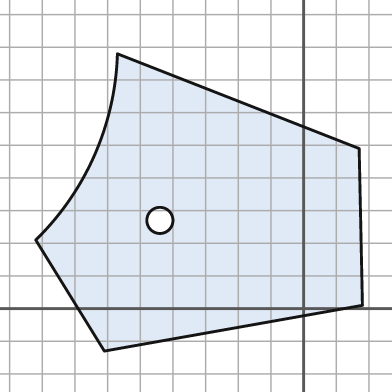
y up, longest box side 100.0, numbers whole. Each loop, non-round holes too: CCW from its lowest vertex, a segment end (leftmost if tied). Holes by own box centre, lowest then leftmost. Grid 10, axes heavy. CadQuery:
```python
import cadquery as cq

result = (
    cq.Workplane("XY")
    .moveTo(-61.0, -13.0)
    .lineTo(18.0, 1.0)
    .lineTo(17.0, 49.0)
    .lineTo(-57.0, 78.0)
    .threePointArc((-64.0, 47.0), (-82.0, 21.0))
    .close()
    .moveTo(-44.0, 27.0)
    .circle(4.0)
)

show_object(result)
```